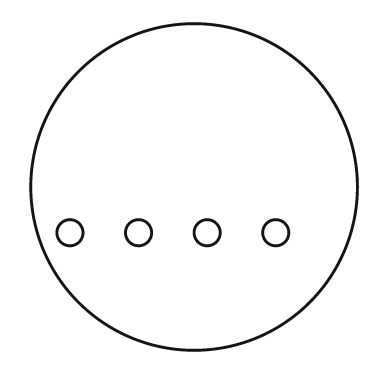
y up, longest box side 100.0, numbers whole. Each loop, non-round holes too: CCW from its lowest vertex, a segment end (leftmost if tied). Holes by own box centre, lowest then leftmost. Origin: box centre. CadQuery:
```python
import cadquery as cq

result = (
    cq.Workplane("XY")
    .moveTo(0.0, 0.0)
    .circle(50.0)
    .moveTo(-38.0, -14.0)
    .circle(4.0)
    .moveTo(-17.0, -14.0)
    .circle(4.0)
    .moveTo(4.0, -14.0)
    .circle(4.0)
    .moveTo(25.0, -14.0)
    .circle(4.0)
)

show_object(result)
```